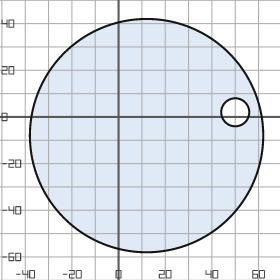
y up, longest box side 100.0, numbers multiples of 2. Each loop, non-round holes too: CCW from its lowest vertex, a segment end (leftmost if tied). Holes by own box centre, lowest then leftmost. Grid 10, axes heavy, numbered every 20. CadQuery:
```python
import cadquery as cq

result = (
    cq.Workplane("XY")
    .moveTo(12.0, -8.0)
    .circle(50.0)
    .moveTo(50.0, 2.0)
    .circle(6.0)
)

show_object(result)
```